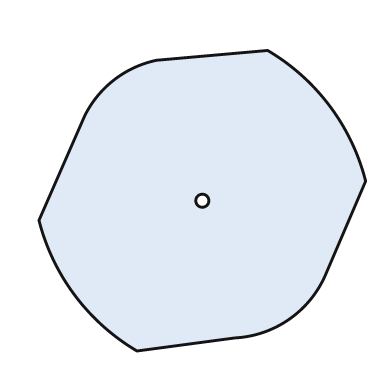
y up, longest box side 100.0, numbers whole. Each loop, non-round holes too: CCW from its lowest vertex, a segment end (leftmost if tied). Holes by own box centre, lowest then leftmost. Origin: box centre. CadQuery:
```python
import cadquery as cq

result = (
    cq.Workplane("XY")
    .moveTo(-20.0, -46.0)
    .lineTo(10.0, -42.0)
    .threePointArc((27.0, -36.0), (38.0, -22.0))
    .lineTo(50.0, 6.0)
    .threePointArc((39.0, 29.0), (20.0, 46.0))
    .lineTo(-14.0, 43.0)
    .threePointArc((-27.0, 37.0), (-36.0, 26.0))
    .lineTo(-50.0, -6.0)
    .threePointArc((-39.0, -29.0), (-20.0, -46.0))
    .close()
    .moveTo(0.0, 0.0)
    .circle(2.0)
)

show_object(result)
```